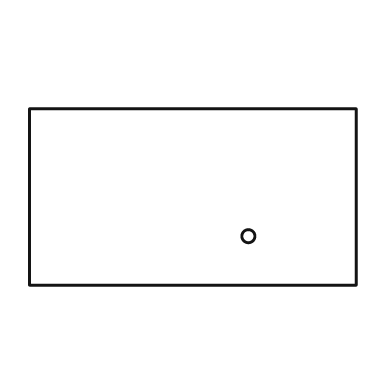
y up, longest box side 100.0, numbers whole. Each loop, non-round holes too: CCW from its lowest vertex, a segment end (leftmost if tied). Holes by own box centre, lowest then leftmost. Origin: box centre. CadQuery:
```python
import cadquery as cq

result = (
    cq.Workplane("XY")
    .moveTo(-50.0, -27.0)
    .lineTo(50.0, -27.0)
    .lineTo(50.0, 27.0)
    .lineTo(-50.0, 27.0)
    .close()
    .moveTo(17.0, -12.0)
    .circle(2.0)
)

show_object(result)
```